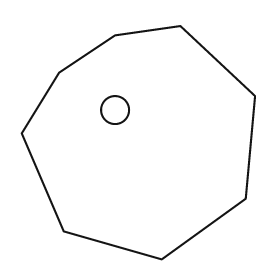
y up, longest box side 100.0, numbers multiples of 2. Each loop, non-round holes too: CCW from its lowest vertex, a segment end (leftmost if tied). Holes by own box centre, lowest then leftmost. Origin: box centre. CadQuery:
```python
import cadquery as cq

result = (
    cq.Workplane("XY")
    .moveTo(10.0, -50.0)
    .lineTo(46.0, -24.0)
    .lineTo(50.0, 20.0)
    .lineTo(18.0, 50.0)
    .lineTo(-10.0, 46.0)
    .lineTo(-34.0, 30.0)
    .lineTo(-50.0, 4.0)
    .lineTo(-32.0, -38.0)
    .close()
    .moveTo(-10.0, 14.0)
    .circle(6.0)
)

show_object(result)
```